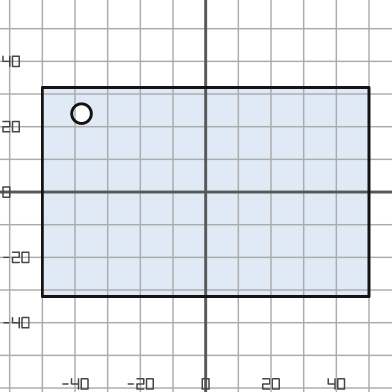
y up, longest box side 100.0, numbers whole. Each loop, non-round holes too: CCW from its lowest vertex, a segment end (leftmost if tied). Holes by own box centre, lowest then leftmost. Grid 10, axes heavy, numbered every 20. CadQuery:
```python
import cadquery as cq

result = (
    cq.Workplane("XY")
    .moveTo(-50.0, -32.0)
    .lineTo(50.0, -32.0)
    .lineTo(50.0, 32.0)
    .lineTo(-50.0, 32.0)
    .close()
    .moveTo(-38.0, 24.0)
    .circle(3.0)
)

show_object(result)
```